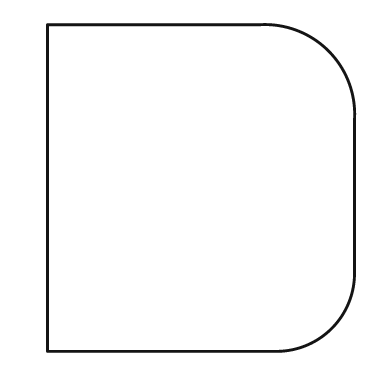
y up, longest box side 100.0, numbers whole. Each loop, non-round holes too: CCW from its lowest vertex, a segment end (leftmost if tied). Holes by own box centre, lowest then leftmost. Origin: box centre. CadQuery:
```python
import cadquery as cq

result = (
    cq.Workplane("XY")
    .moveTo(-47.0, -50.0)
    .lineTo(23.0, -50.0)
    .threePointArc((40.0, -43.0), (47.0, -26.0))
    .lineTo(47.0, 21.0)
    .threePointArc((39.0, 42.0), (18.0, 50.0))
    .lineTo(-47.0, 50.0)
    .close()
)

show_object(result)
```